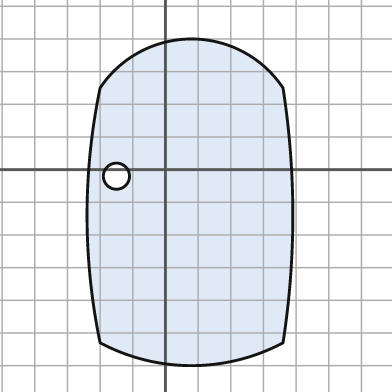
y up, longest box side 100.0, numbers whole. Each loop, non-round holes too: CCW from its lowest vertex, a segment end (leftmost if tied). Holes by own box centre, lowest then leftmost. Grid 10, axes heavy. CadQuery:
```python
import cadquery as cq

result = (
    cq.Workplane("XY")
    .moveTo(-20.0, -53.0)
    .threePointArc((8.0, -60.0), (36.0, -53.0))
    .threePointArc((39.0, -14.0), (36.0, 25.0))
    .threePointArc((8.0, 40.0), (-20.0, 25.0))
    .threePointArc((-24.0, -14.0), (-20.0, -53.0))
    .close()
    .moveTo(-15.0, -2.0)
    .circle(4.0)
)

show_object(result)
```